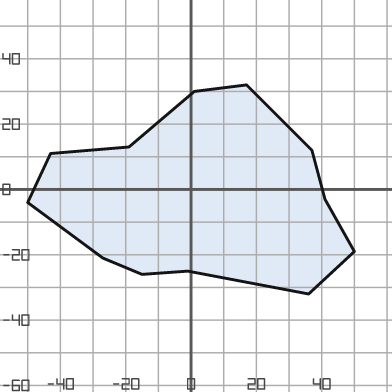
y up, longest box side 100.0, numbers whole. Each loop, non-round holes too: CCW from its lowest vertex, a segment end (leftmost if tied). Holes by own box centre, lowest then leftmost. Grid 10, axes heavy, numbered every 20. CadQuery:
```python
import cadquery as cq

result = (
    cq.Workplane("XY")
    .moveTo(36.0, -32.0)
    .lineTo(50.0, -19.0)
    .lineTo(41.0, -3.0)
    .lineTo(37.0, 12.0)
    .lineTo(17.0, 32.0)
    .lineTo(1.0, 30.0)
    .lineTo(-19.0, 13.0)
    .lineTo(-43.0, 11.0)
    .lineTo(-50.0, -4.0)
    .lineTo(-27.0, -21.0)
    .lineTo(-15.0, -26.0)
    .lineTo(-1.0, -25.0)
    .close()
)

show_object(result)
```